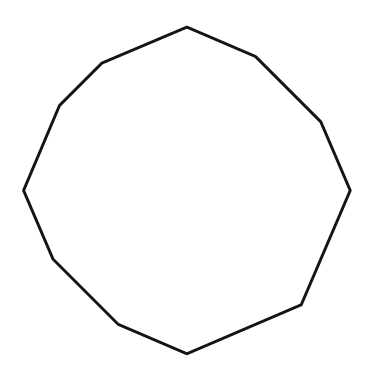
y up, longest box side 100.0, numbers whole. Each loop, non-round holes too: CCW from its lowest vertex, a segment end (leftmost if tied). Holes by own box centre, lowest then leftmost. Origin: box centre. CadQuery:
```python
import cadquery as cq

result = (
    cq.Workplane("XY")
    .moveTo(0.0, -50.0)
    .lineTo(35.0, -35.0)
    .lineTo(50.0, 0.0)
    .lineTo(41.0, 21.0)
    .lineTo(21.0, 41.0)
    .lineTo(0.0, 50.0)
    .lineTo(-26.0, 39.0)
    .lineTo(-39.0, 26.0)
    .lineTo(-50.0, 0.0)
    .lineTo(-41.0, -21.0)
    .lineTo(-21.0, -41.0)
    .close()
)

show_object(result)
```